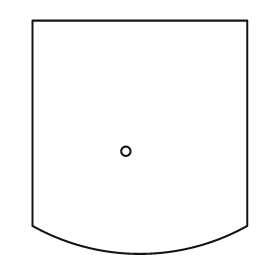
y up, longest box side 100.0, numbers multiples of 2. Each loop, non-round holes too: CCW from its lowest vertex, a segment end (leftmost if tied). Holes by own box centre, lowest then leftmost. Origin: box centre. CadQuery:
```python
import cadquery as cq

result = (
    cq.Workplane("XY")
    .moveTo(-46.0, -38.0)
    .threePointArc((0.0, -50.0), (46.0, -38.0))
    .lineTo(46.0, 50.0)
    .lineTo(-46.0, 50.0)
    .close()
    .moveTo(-6.0, -6.0)
    .circle(2.0)
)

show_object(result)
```